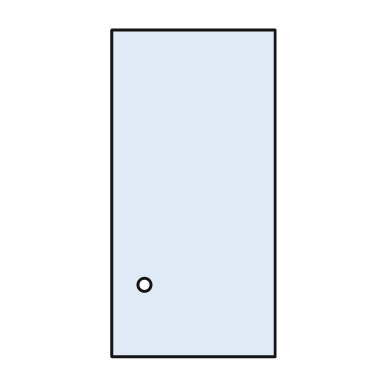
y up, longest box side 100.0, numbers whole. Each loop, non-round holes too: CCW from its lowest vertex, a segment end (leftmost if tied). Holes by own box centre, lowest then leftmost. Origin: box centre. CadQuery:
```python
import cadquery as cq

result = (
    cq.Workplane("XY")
    .moveTo(-25.0, -50.0)
    .lineTo(25.0, -50.0)
    .lineTo(25.0, 50.0)
    .lineTo(-25.0, 50.0)
    .close()
    .moveTo(-15.0, -28.0)
    .circle(2.0)
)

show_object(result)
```